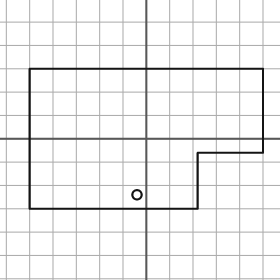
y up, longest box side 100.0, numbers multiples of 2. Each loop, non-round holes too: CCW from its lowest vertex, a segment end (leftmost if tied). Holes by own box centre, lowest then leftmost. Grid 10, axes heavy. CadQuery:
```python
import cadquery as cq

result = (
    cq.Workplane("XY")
    .moveTo(-50.0, -30.0)
    .lineTo(22.0, -30.0)
    .lineTo(22.0, -6.0)
    .lineTo(50.0, -6.0)
    .lineTo(50.0, 30.0)
    .lineTo(-50.0, 30.0)
    .close()
    .moveTo(-4.0, -24.0)
    .circle(2.0)
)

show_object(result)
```